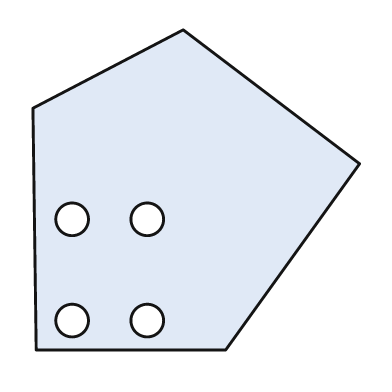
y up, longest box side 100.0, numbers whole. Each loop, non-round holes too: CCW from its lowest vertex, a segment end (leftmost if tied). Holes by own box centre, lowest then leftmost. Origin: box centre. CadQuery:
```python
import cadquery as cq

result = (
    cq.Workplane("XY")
    .moveTo(-49.0, -49.0)
    .lineTo(9.0, -49.0)
    .lineTo(50.0, 8.0)
    .lineTo(-4.0, 49.0)
    .lineTo(-50.0, 25.0)
    .close()
    .moveTo(-38.0, -40.0)
    .circle(5.0)
    .moveTo(-15.0, -40.0)
    .circle(5.0)
    .moveTo(-38.0, -9.0)
    .circle(5.0)
    .moveTo(-15.0, -9.0)
    .circle(5.0)
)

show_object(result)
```